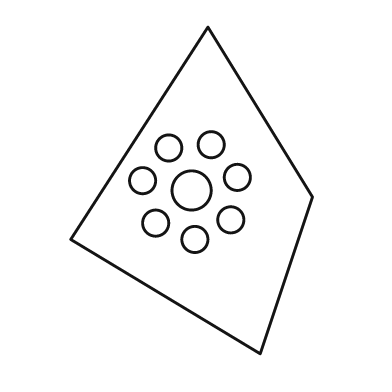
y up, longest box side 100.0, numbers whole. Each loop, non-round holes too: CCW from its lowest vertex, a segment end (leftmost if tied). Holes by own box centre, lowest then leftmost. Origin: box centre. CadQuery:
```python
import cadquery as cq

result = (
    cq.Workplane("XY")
    .moveTo(21.0, -50.0)
    .lineTo(37.0, -2.0)
    .lineTo(5.0, 50.0)
    .lineTo(-37.0, -15.0)
    .close()
    .moveTo(1.0, -15.0)
    .circle(4.0)
    .moveTo(-11.0, -10.0)
    .circle(4.0)
    .moveTo(12.0, -9.0)
    .circle(4.0)
    .moveTo(0.0, 0.0)
    .circle(6.0)
    .moveTo(-15.0, 3.0)
    .circle(4.0)
    .moveTo(14.0, 4.0)
    .circle(4.0)
    .moveTo(-7.0, 13.0)
    .circle(4.0)
    .moveTo(6.0, 14.0)
    .circle(4.0)
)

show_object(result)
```